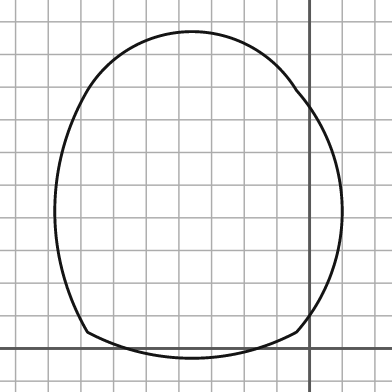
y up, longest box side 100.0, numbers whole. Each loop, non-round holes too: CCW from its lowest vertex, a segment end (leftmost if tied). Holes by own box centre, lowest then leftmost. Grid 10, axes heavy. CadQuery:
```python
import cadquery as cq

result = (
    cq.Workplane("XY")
    .moveTo(-68.0, 5.0)
    .threePointArc((-36.0, -3.0), (-4.0, 5.0))
    .threePointArc((10.0, 42.0), (-4.0, 79.0))
    .threePointArc((-36.0, 97.0), (-68.0, 79.0))
    .threePointArc((-78.0, 42.0), (-68.0, 5.0))
    .close()
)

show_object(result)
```